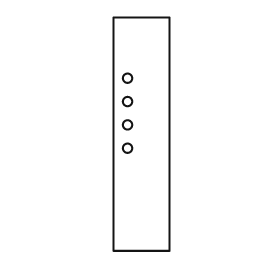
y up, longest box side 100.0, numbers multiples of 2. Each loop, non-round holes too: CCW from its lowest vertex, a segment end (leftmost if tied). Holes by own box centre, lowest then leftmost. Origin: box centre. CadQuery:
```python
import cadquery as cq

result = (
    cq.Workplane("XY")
    .moveTo(-12.0, -50.0)
    .lineTo(12.0, -50.0)
    .lineTo(12.0, 50.0)
    .lineTo(-12.0, 50.0)
    .close()
    .moveTo(-6.0, -6.0)
    .circle(2.0)
    .moveTo(-6.0, 4.0)
    .circle(2.0)
    .moveTo(-6.0, 14.0)
    .circle(2.0)
    .moveTo(-6.0, 24.0)
    .circle(2.0)
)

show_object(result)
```